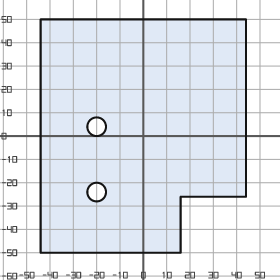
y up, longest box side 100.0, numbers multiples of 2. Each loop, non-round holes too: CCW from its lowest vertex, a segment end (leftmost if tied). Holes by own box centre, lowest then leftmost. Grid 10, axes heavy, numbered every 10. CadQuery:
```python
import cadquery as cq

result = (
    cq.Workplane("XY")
    .moveTo(-44.0, -50.0)
    .lineTo(16.0, -50.0)
    .lineTo(16.0, -26.0)
    .lineTo(44.0, -26.0)
    .lineTo(44.0, 50.0)
    .lineTo(-44.0, 50.0)
    .close()
    .moveTo(-20.0, -24.0)
    .circle(4.0)
    .moveTo(-20.0, 4.0)
    .circle(4.0)
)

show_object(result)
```